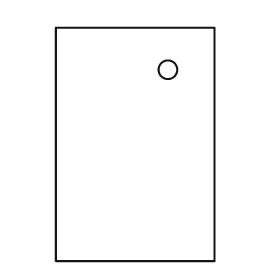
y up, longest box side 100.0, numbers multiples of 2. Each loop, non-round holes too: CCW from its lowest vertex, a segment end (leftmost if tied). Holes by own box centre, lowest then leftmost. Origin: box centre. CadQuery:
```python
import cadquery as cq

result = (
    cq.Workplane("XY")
    .moveTo(-34.0, -50.0)
    .lineTo(34.0, -50.0)
    .lineTo(34.0, 50.0)
    .lineTo(-34.0, 50.0)
    .close()
    .moveTo(14.0, 32.0)
    .circle(4.0)
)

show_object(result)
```